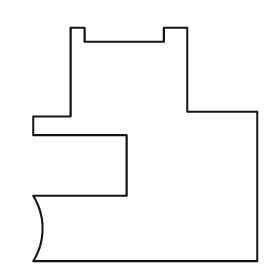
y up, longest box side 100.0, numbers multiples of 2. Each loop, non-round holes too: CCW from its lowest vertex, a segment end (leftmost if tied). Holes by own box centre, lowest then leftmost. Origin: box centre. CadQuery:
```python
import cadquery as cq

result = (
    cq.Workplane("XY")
    .moveTo(-48.0, -50.0)
    .lineTo(48.0, -50.0)
    .lineTo(48.0, 14.0)
    .lineTo(18.0, 14.0)
    .lineTo(18.0, 50.0)
    .lineTo(8.0, 50.0)
    .lineTo(8.0, 44.0)
    .lineTo(-26.0, 44.0)
    .lineTo(-26.0, 50.0)
    .lineTo(-32.0, 50.0)
    .lineTo(-32.0, 12.0)
    .lineTo(-48.0, 12.0)
    .lineTo(-48.0, 4.0)
    .lineTo(-8.0, 4.0)
    .lineTo(-8.0, -22.0)
    .lineTo(-48.0, -22.0)
    .threePointArc((-44.0, -36.0), (-48.0, -50.0))
    .close()
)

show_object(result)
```